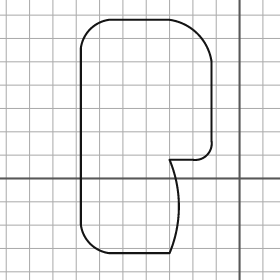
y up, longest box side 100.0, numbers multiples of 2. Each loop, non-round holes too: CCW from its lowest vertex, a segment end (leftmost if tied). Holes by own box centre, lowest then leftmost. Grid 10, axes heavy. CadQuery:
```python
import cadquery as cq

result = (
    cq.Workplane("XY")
    .moveTo(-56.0, -32.0)
    .lineTo(-30.0, -32.0)
    .threePointArc((-26.0, -12.0), (-30.0, 8.0))
    .lineTo(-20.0, 8.0)
    .threePointArc((-14.0, 10.0), (-12.0, 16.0))
    .lineTo(-12.0, 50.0)
    .threePointArc((-18.0, 62.0), (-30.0, 68.0))
    .lineTo(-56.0, 68.0)
    .threePointArc((-64.0, 64.0), (-68.0, 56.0))
    .lineTo(-68.0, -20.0)
    .threePointArc((-64.0, -28.0), (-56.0, -32.0))
    .close()
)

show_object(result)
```